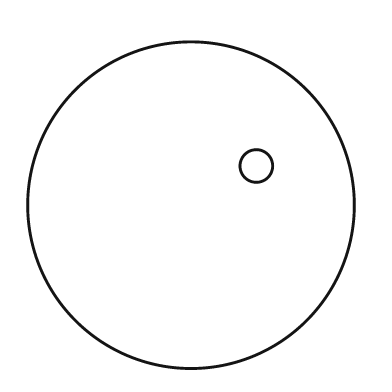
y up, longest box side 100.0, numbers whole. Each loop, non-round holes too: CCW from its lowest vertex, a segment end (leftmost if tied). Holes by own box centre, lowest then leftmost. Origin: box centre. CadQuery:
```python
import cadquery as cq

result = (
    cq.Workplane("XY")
    .moveTo(0.0, 0.0)
    .circle(50.0)
    .moveTo(20.0, 12.0)
    .circle(5.0)
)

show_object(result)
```